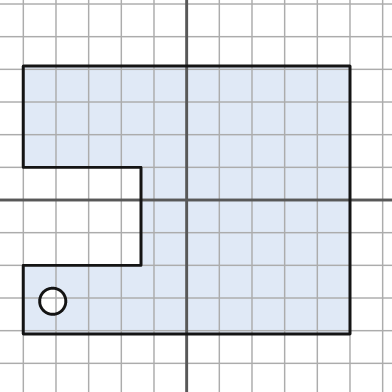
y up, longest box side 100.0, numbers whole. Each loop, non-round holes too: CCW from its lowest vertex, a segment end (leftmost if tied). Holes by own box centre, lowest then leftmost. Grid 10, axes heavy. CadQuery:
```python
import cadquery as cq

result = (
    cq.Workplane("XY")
    .moveTo(-50.0, -41.0)
    .lineTo(50.0, -41.0)
    .lineTo(50.0, 41.0)
    .lineTo(-50.0, 41.0)
    .lineTo(-50.0, 10.0)
    .lineTo(-14.0, 10.0)
    .lineTo(-14.0, -20.0)
    .lineTo(-50.0, -20.0)
    .close()
    .moveTo(-41.0, -31.0)
    .circle(4.0)
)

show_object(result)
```